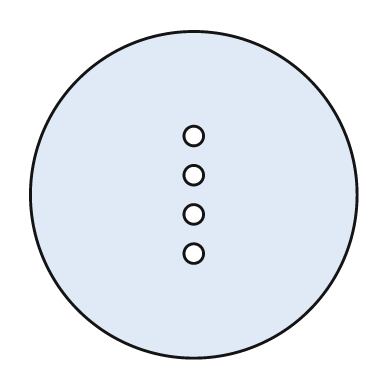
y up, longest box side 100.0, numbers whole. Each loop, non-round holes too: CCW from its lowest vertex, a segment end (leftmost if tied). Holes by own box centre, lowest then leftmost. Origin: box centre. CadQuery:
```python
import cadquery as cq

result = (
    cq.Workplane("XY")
    .moveTo(0.0, 0.0)
    .circle(50.0)
    .moveTo(0.0, -18.0)
    .circle(3.0)
    .moveTo(0.0, -6.0)
    .circle(3.0)
    .moveTo(0.0, 6.0)
    .circle(3.0)
    .moveTo(0.0, 18.0)
    .circle(3.0)
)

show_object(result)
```